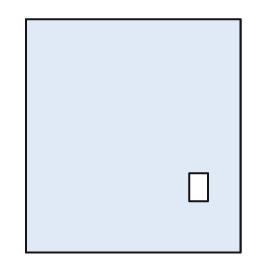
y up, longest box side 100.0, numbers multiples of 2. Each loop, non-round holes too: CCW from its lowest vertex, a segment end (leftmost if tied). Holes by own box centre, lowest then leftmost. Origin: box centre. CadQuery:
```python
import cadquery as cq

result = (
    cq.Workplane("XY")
    .moveTo(-46.0, -50.0)
    .lineTo(46.0, -50.0)
    .lineTo(46.0, 50.0)
    .lineTo(-46.0, 50.0)
    .close()
    .moveTo(24.0, -28.0)
    .lineTo(32.0, -28.0)
    .lineTo(32.0, -16.0)
    .lineTo(24.0, -16.0)
    .close()
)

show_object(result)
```